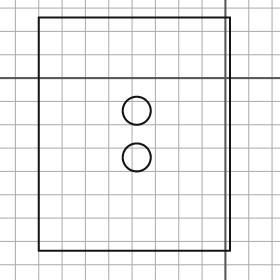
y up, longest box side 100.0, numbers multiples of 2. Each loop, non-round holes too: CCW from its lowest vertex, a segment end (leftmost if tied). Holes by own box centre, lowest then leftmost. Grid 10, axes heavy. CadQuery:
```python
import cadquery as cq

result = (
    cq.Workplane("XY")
    .moveTo(-80.0, -74.0)
    .lineTo(2.0, -74.0)
    .lineTo(2.0, 26.0)
    .lineTo(-80.0, 26.0)
    .close()
    .moveTo(-38.0, -34.0)
    .circle(6.0)
    .moveTo(-38.0, -14.0)
    .circle(6.0)
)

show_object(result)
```